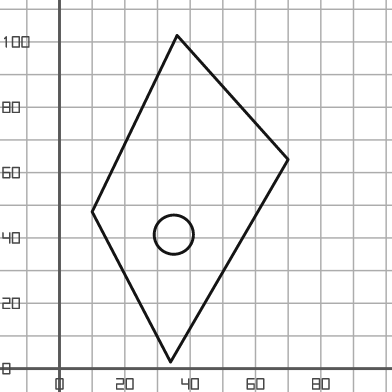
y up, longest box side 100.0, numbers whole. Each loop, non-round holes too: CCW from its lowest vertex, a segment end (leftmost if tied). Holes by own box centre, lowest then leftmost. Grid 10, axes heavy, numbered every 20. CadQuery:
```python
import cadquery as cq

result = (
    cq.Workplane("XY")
    .moveTo(34.0, 2.0)
    .lineTo(70.0, 64.0)
    .lineTo(36.0, 102.0)
    .lineTo(10.0, 48.0)
    .close()
    .moveTo(35.0, 41.0)
    .circle(6.0)
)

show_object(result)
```